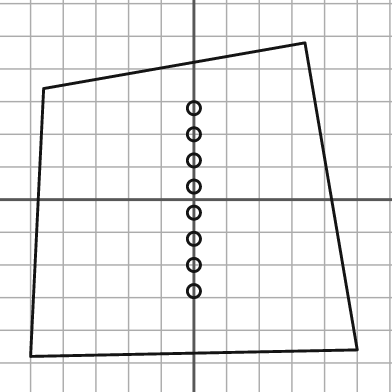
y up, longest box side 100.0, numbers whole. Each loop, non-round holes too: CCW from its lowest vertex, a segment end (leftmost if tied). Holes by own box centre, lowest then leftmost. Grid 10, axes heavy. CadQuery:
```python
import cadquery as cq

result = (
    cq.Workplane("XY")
    .moveTo(-50.0, -48.0)
    .lineTo(50.0, -46.0)
    .lineTo(34.0, 48.0)
    .lineTo(-46.0, 34.0)
    .close()
    .moveTo(0.0, -28.0)
    .circle(2.0)
    .moveTo(0.0, -20.0)
    .circle(2.0)
    .moveTo(0.0, -12.0)
    .circle(2.0)
    .moveTo(0.0, -4.0)
    .circle(2.0)
    .moveTo(0.0, 4.0)
    .circle(2.0)
    .moveTo(0.0, 12.0)
    .circle(2.0)
    .moveTo(0.0, 20.0)
    .circle(2.0)
    .moveTo(0.0, 28.0)
    .circle(2.0)
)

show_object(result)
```